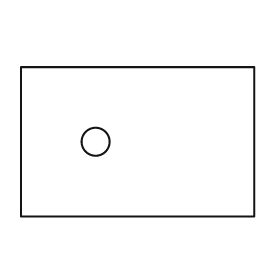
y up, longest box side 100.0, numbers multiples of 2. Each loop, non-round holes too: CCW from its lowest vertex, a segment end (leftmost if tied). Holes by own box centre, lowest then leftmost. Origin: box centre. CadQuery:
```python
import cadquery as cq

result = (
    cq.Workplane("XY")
    .moveTo(-50.0, -32.0)
    .lineTo(50.0, -32.0)
    .lineTo(50.0, 32.0)
    .lineTo(-50.0, 32.0)
    .close()
    .moveTo(-18.0, 0.0)
    .circle(6.0)
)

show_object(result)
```